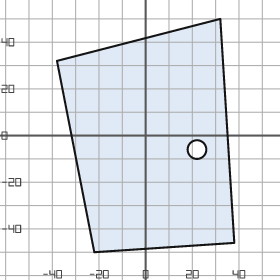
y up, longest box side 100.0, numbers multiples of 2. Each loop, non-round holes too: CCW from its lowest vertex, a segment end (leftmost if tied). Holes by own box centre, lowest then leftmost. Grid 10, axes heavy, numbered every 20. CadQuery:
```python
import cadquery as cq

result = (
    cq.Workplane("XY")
    .moveTo(-22.0, -50.0)
    .lineTo(38.0, -46.0)
    .lineTo(32.0, 50.0)
    .lineTo(-38.0, 32.0)
    .close()
    .moveTo(22.0, -6.0)
    .circle(4.0)
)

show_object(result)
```